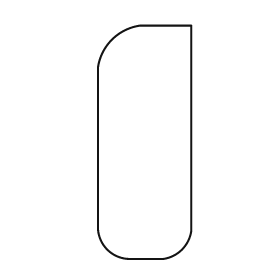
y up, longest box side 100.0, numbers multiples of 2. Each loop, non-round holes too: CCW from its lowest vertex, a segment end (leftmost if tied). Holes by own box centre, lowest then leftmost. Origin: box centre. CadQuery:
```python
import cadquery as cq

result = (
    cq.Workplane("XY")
    .moveTo(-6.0, -50.0)
    .lineTo(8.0, -50.0)
    .threePointArc((16.0, -46.0), (20.0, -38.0))
    .lineTo(20.0, 50.0)
    .lineTo(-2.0, 50.0)
    .threePointArc((-14.0, 44.0), (-20.0, 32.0))
    .lineTo(-20.0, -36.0)
    .threePointArc((-16.0, -46.0), (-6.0, -50.0))
    .close()
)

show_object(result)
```